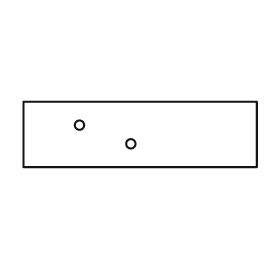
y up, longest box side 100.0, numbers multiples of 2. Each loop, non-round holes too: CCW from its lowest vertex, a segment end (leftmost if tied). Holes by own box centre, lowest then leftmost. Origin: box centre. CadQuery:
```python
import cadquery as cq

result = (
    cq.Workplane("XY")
    .moveTo(-50.0, -14.0)
    .lineTo(50.0, -14.0)
    .lineTo(50.0, 14.0)
    .lineTo(-50.0, 14.0)
    .close()
    .moveTo(-4.0, -4.0)
    .circle(2.0)
    .moveTo(-26.0, 4.0)
    .circle(2.0)
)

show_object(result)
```